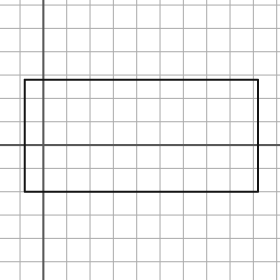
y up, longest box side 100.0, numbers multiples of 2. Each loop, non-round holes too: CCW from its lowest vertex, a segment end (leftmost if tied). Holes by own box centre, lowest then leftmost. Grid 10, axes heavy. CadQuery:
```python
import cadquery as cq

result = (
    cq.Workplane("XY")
    .moveTo(-8.0, -20.0)
    .lineTo(92.0, -20.0)
    .lineTo(92.0, 28.0)
    .lineTo(-8.0, 28.0)
    .close()
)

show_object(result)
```